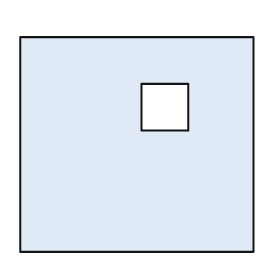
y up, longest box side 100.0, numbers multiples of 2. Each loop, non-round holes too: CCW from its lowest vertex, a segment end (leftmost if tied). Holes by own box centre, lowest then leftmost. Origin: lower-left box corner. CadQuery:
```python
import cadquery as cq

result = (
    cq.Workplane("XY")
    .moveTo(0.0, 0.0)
    .lineTo(100.0, 0.0)
    .lineTo(100.0, 92.0)
    .lineTo(0.0, 92.0)
    .close()
    .moveTo(52.0, 52.0)
    .lineTo(72.0, 52.0)
    .lineTo(72.0, 72.0)
    .lineTo(52.0, 72.0)
    .close()
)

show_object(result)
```